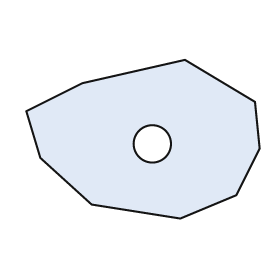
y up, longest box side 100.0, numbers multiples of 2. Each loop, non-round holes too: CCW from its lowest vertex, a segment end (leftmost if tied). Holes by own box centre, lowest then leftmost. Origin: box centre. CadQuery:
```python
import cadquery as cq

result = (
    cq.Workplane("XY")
    .moveTo(16.0, -34.0)
    .lineTo(40.0, -24.0)
    .lineTo(50.0, -4.0)
    .lineTo(48.0, 16.0)
    .lineTo(18.0, 34.0)
    .lineTo(-26.0, 24.0)
    .lineTo(-50.0, 12.0)
    .lineTo(-44.0, -8.0)
    .lineTo(-22.0, -28.0)
    .close()
    .moveTo(4.0, -2.0)
    .circle(8.0)
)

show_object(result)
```